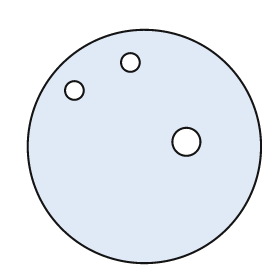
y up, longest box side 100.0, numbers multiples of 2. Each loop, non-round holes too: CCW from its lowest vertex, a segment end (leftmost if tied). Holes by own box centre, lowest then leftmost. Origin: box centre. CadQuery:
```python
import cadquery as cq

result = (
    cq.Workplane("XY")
    .moveTo(0.0, 0.0)
    .circle(50.0)
    .moveTo(18.0, 2.0)
    .circle(6.0)
    .moveTo(-30.0, 24.0)
    .circle(4.0)
    .moveTo(-6.0, 36.0)
    .circle(4.0)
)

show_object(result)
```